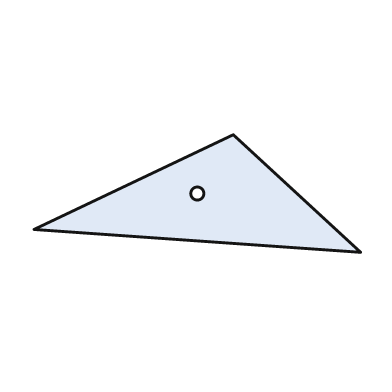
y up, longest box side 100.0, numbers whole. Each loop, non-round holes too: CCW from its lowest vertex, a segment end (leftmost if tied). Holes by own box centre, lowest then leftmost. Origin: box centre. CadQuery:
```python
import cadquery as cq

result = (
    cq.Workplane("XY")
    .moveTo(50.0, -18.0)
    .lineTo(11.0, 18.0)
    .lineTo(-50.0, -11.0)
    .close()
    .moveTo(0.0, 0.0)
    .circle(2.0)
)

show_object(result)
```